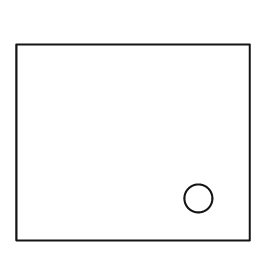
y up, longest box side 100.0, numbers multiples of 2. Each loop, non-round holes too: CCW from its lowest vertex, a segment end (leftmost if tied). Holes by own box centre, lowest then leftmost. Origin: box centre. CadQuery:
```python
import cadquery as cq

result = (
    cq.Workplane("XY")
    .moveTo(-50.0, -42.0)
    .lineTo(50.0, -42.0)
    .lineTo(50.0, 42.0)
    .lineTo(-50.0, 42.0)
    .close()
    .moveTo(28.0, -24.0)
    .circle(6.0)
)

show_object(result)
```